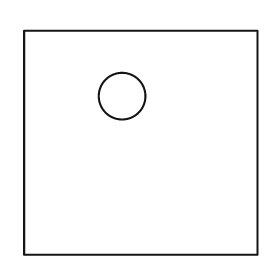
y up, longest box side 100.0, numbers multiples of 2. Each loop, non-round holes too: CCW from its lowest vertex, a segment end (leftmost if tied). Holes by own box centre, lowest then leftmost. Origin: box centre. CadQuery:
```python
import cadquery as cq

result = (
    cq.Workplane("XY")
    .moveTo(-50.0, -48.0)
    .lineTo(50.0, -48.0)
    .lineTo(50.0, 48.0)
    .lineTo(-50.0, 48.0)
    .close()
    .moveTo(-8.0, 20.0)
    .circle(10.0)
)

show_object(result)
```